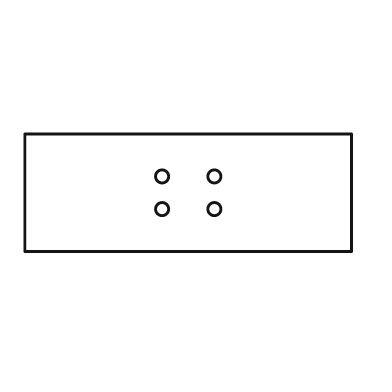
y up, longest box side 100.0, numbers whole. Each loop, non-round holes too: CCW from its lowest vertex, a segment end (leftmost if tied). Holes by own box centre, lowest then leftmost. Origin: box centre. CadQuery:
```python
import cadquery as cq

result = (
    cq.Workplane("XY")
    .moveTo(-50.0, -18.0)
    .lineTo(50.0, -18.0)
    .lineTo(50.0, 18.0)
    .lineTo(-50.0, 18.0)
    .close()
    .moveTo(-8.0, -5.0)
    .circle(2.0)
    .moveTo(8.0, -5.0)
    .circle(2.0)
    .moveTo(-8.0, 5.0)
    .circle(2.0)
    .moveTo(8.0, 5.0)
    .circle(2.0)
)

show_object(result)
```